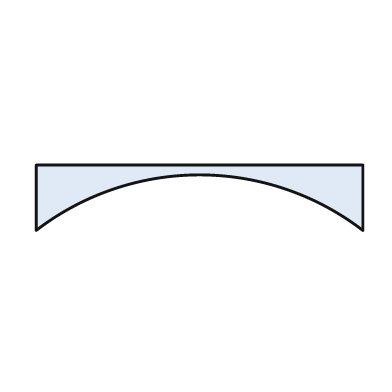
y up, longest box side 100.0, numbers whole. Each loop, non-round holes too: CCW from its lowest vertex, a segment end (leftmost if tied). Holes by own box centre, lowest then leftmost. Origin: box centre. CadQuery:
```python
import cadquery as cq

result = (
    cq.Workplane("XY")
    .moveTo(-50.0, -10.0)
    .threePointArc((0.0, 7.0), (50.0, -10.0))
    .lineTo(50.0, 10.0)
    .lineTo(-50.0, 10.0)
    .close()
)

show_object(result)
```